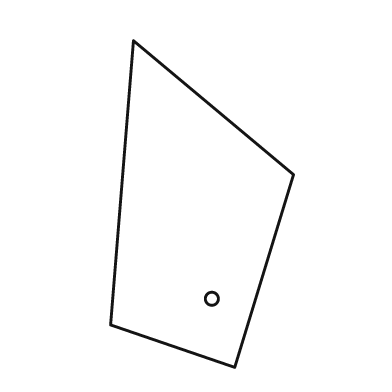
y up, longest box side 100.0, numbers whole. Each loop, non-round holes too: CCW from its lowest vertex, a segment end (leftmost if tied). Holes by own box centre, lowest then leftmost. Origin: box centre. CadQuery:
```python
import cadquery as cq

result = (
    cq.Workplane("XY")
    .moveTo(10.0, -50.0)
    .lineTo(28.0, 9.0)
    .lineTo(-21.0, 50.0)
    .lineTo(-28.0, -37.0)
    .close()
    .moveTo(3.0, -29.0)
    .circle(2.0)
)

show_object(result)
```